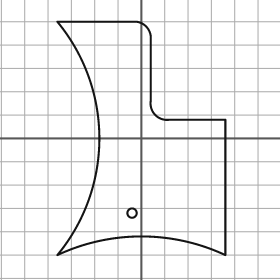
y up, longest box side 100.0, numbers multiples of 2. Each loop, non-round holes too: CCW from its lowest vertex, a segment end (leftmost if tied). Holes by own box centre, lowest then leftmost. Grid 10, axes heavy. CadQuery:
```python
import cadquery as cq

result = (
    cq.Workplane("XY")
    .moveTo(-36.0, -50.0)
    .threePointArc((0.0, -42.0), (36.0, -50.0))
    .lineTo(36.0, 8.0)
    .lineTo(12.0, 8.0)
    .threePointArc((6.0, 10.0), (4.0, 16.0))
    .lineTo(4.0, 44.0)
    .threePointArc((2.0, 48.0), (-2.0, 50.0))
    .lineTo(-36.0, 50.0)
    .threePointArc((-18.0, 0.0), (-36.0, -50.0))
    .close()
    .moveTo(-4.0, -32.0)
    .circle(2.0)
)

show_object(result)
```